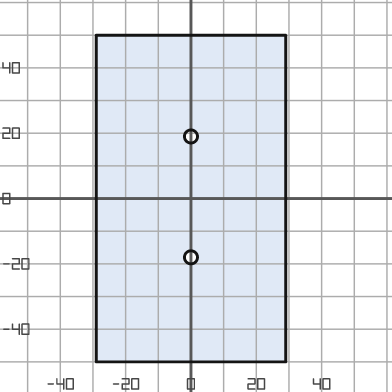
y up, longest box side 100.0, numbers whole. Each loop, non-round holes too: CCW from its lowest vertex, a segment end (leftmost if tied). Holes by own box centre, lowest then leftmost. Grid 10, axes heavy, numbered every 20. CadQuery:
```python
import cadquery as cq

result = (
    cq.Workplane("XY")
    .moveTo(-29.0, -50.0)
    .lineTo(29.0, -50.0)
    .lineTo(29.0, 50.0)
    .lineTo(-29.0, 50.0)
    .close()
    .moveTo(0.0, -18.0)
    .circle(2.0)
    .moveTo(0.0, 19.0)
    .circle(2.0)
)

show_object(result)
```